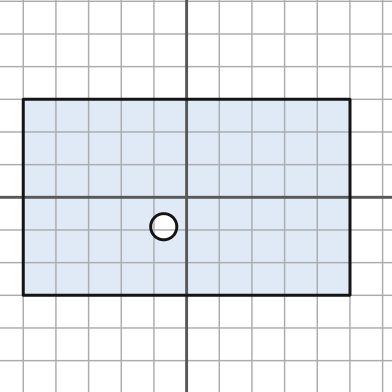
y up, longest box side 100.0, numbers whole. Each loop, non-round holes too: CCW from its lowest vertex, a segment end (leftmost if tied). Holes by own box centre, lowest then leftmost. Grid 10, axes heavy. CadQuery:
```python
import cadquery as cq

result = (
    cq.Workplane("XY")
    .moveTo(-50.0, -30.0)
    .lineTo(50.0, -30.0)
    .lineTo(50.0, 30.0)
    .lineTo(-50.0, 30.0)
    .close()
    .moveTo(-7.0, -9.0)
    .circle(4.0)
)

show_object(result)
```